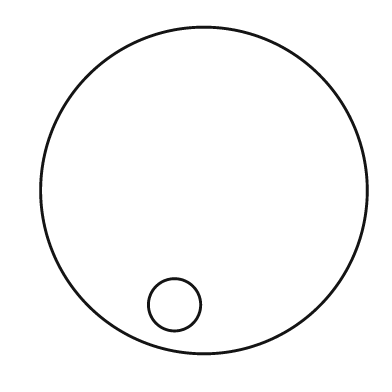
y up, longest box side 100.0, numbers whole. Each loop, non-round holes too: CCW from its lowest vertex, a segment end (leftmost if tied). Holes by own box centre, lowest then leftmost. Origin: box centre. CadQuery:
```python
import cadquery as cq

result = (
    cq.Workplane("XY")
    .moveTo(0.0, 0.0)
    .circle(50.0)
    .moveTo(-9.0, -35.0)
    .circle(8.0)
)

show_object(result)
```